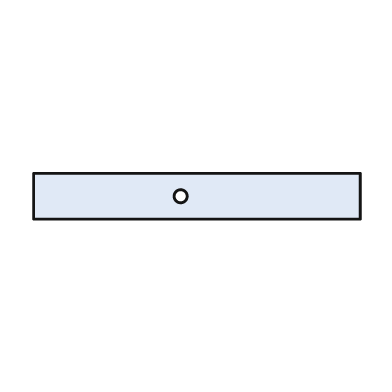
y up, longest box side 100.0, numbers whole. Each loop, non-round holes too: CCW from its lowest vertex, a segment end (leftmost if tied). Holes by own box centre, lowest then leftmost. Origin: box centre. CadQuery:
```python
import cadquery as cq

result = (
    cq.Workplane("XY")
    .moveTo(-50.0, -7.0)
    .lineTo(50.0, -7.0)
    .lineTo(50.0, 7.0)
    .lineTo(-50.0, 7.0)
    .close()
    .moveTo(-5.0, 0.0)
    .circle(2.0)
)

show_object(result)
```